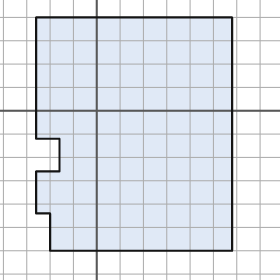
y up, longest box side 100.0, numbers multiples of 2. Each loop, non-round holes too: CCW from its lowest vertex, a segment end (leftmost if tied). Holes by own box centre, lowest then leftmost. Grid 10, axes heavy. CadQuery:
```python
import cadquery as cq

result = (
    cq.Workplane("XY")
    .moveTo(-20.0, -60.0)
    .lineTo(58.0, -60.0)
    .lineTo(58.0, 40.0)
    .lineTo(-26.0, 40.0)
    .lineTo(-26.0, -12.0)
    .lineTo(-16.0, -12.0)
    .lineTo(-16.0, -26.0)
    .lineTo(-26.0, -26.0)
    .lineTo(-26.0, -44.0)
    .lineTo(-20.0, -44.0)
    .close()
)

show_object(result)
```